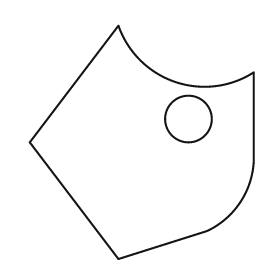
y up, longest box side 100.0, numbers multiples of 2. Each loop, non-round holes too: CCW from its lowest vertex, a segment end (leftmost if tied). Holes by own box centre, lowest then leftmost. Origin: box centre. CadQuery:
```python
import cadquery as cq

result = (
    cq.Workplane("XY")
    .moveTo(-10.0, -50.0)
    .lineTo(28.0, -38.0)
    .threePointArc((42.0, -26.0), (48.0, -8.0))
    .lineTo(48.0, 30.0)
    .threePointArc((14.0, 26.0), (-10.0, 50.0))
    .lineTo(-48.0, 0.0)
    .close()
    .moveTo(20.0, 10.0)
    .circle(10.0)
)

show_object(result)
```